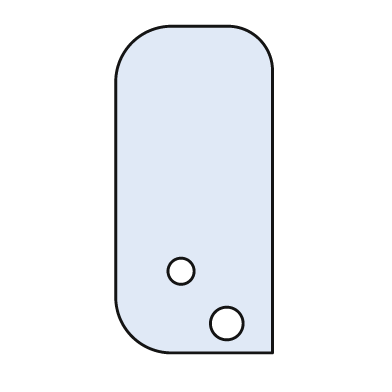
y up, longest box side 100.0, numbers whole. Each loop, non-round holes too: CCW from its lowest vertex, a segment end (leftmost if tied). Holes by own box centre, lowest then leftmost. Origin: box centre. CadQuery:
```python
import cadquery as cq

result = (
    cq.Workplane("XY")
    .moveTo(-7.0, -50.0)
    .lineTo(24.0, -50.0)
    .lineTo(24.0, 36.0)
    .threePointArc((20.0, 46.0), (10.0, 50.0))
    .lineTo(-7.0, 50.0)
    .threePointArc((-19.0, 45.0), (-24.0, 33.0))
    .lineTo(-24.0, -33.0)
    .threePointArc((-19.0, -45.0), (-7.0, -50.0))
    .close()
    .moveTo(10.0, -41.0)
    .circle(5.0)
    .moveTo(-4.0, -25.0)
    .circle(4.0)
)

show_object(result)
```